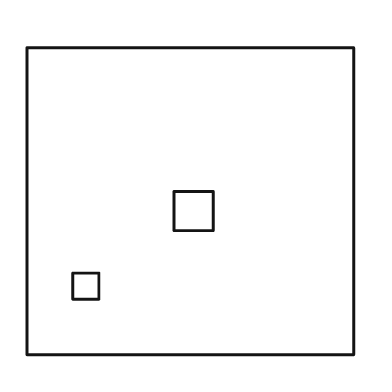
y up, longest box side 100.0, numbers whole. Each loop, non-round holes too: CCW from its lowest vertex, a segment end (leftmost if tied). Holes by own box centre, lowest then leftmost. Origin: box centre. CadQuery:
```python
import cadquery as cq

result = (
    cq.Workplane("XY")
    .moveTo(-50.0, -47.0)
    .lineTo(50.0, -47.0)
    .lineTo(50.0, 47.0)
    .lineTo(-50.0, 47.0)
    .close()
    .moveTo(-36.0, -30.0)
    .lineTo(-28.0, -30.0)
    .lineTo(-28.0, -22.0)
    .lineTo(-36.0, -22.0)
    .close()
    .moveTo(-5.0, -9.0)
    .lineTo(7.0, -9.0)
    .lineTo(7.0, 3.0)
    .lineTo(-5.0, 3.0)
    .close()
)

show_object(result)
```